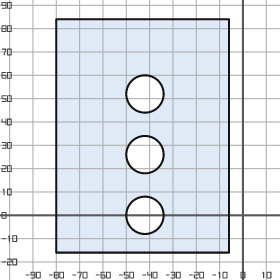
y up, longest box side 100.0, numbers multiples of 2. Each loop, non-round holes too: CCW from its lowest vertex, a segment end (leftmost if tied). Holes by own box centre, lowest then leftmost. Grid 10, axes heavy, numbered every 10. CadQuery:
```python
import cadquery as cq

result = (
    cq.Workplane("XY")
    .moveTo(-80.0, -16.0)
    .lineTo(-6.0, -16.0)
    .lineTo(-6.0, 84.0)
    .lineTo(-80.0, 84.0)
    .close()
    .moveTo(-42.0, 0.0)
    .circle(8.0)
    .moveTo(-42.0, 26.0)
    .circle(8.0)
    .moveTo(-42.0, 52.0)
    .circle(8.0)
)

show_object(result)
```